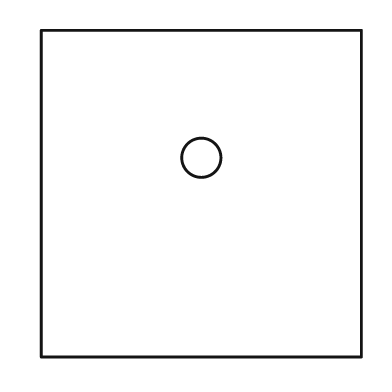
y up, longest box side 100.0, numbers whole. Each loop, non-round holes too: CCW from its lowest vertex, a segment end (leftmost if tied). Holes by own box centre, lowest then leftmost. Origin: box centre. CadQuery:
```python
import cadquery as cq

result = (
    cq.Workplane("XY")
    .moveTo(-49.0, -50.0)
    .lineTo(49.0, -50.0)
    .lineTo(49.0, 50.0)
    .lineTo(-49.0, 50.0)
    .close()
    .moveTo(0.0, 11.0)
    .circle(6.0)
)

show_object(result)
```